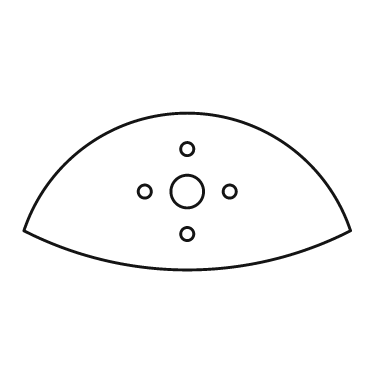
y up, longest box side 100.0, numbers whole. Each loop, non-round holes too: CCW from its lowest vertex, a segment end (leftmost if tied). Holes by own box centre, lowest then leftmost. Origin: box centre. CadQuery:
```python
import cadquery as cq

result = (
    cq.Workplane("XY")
    .moveTo(-50.0, -12.0)
    .threePointArc((0.0, -24.0), (50.0, -12.0))
    .threePointArc((0.0, 24.0), (-50.0, -12.0))
    .close()
    .moveTo(0.0, -13.0)
    .circle(2.0)
    .moveTo(-13.0, 0.0)
    .circle(2.0)
    .moveTo(0.0, 0.0)
    .circle(5.0)
    .moveTo(13.0, 0.0)
    .circle(2.0)
    .moveTo(0.0, 13.0)
    .circle(2.0)
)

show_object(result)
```